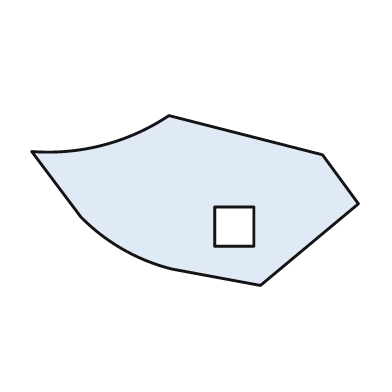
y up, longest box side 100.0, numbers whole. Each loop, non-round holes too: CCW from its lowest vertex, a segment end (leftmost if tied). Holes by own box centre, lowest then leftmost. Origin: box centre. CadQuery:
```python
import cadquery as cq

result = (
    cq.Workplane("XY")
    .moveTo(20.0, -26.0)
    .lineTo(50.0, -1.0)
    .lineTo(39.0, 14.0)
    .lineTo(-8.0, 26.0)
    .threePointArc((-28.0, 17.0), (-50.0, 15.0))
    .lineTo(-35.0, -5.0)
    .threePointArc((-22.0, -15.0), (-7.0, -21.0))
    .close()
    .moveTo(6.0, -14.0)
    .lineTo(18.0, -14.0)
    .lineTo(18.0, -2.0)
    .lineTo(6.0, -2.0)
    .close()
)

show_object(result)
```